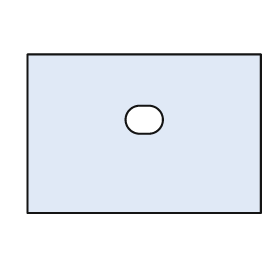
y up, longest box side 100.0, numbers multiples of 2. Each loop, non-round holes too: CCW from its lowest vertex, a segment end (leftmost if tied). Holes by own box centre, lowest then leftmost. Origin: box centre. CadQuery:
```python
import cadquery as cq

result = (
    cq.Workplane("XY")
    .moveTo(-50.0, -34.0)
    .lineTo(50.0, -34.0)
    .lineTo(50.0, 34.0)
    .lineTo(-50.0, 34.0)
    .close()
    .moveTo(-2.0, 0.0)
    .lineTo(2.0, 0.0)
    .threePointArc((8.0, 6.0), (2.0, 12.0))
    .lineTo(-2.0, 12.0)
    .threePointArc((-8.0, 6.0), (-2.0, 0.0))
    .close()
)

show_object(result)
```